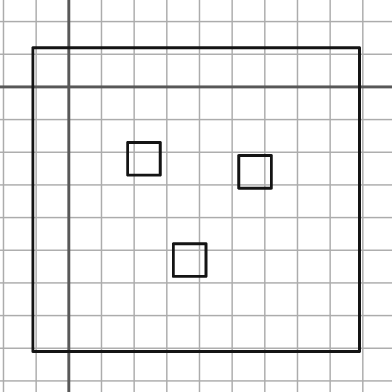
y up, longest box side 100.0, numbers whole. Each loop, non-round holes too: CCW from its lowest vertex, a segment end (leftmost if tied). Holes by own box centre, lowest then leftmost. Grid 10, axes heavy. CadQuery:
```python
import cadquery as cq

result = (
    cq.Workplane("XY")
    .moveTo(-11.0, -81.0)
    .lineTo(89.0, -81.0)
    .lineTo(89.0, 12.0)
    .lineTo(-11.0, 12.0)
    .close()
    .moveTo(32.0, -58.0)
    .lineTo(42.0, -58.0)
    .lineTo(42.0, -48.0)
    .lineTo(32.0, -48.0)
    .close()
    .moveTo(52.0, -31.0)
    .lineTo(62.0, -31.0)
    .lineTo(62.0, -21.0)
    .lineTo(52.0, -21.0)
    .close()
    .moveTo(18.0, -27.0)
    .lineTo(28.0, -27.0)
    .lineTo(28.0, -17.0)
    .lineTo(18.0, -17.0)
    .close()
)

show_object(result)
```